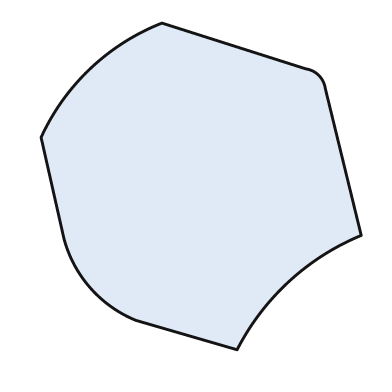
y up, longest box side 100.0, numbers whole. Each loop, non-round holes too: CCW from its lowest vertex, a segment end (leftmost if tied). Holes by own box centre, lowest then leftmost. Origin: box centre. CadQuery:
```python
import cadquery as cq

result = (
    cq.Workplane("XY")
    .moveTo(11.0, -50.0)
    .threePointArc((27.0, -29.0), (49.0, -15.0))
    .lineTo(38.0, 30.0)
    .threePointArc((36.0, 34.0), (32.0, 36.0))
    .lineTo(-12.0, 50.0)
    .threePointArc((-34.0, 36.0), (-49.0, 15.0))
    .lineTo(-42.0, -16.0)
    .threePointArc((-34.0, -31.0), (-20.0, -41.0))
    .close()
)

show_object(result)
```